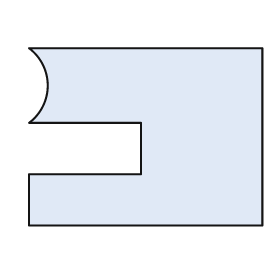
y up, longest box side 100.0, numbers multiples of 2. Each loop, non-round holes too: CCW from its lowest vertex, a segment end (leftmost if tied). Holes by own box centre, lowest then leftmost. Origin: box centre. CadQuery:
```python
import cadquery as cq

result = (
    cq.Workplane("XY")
    .moveTo(-50.0, -38.0)
    .lineTo(50.0, -38.0)
    .lineTo(50.0, 38.0)
    .lineTo(-50.0, 38.0)
    .threePointArc((-42.0, 22.0), (-50.0, 6.0))
    .lineTo(-2.0, 6.0)
    .lineTo(-2.0, -16.0)
    .lineTo(-50.0, -16.0)
    .close()
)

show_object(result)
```